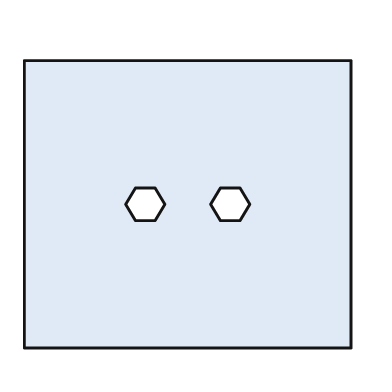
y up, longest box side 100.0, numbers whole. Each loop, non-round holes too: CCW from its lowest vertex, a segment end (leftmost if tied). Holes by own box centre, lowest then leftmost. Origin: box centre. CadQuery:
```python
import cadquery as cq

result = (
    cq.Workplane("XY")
    .moveTo(-50.0, -44.0)
    .lineTo(50.0, -44.0)
    .lineTo(50.0, 44.0)
    .lineTo(-50.0, 44.0)
    .close()
    .moveTo(-16.0, -5.0)
    .lineTo(-10.0, -5.0)
    .lineTo(-7.0, 0.0)
    .lineTo(-10.0, 5.0)
    .lineTo(-16.0, 5.0)
    .lineTo(-19.0, 0.0)
    .close()
    .moveTo(10.0, -5.0)
    .lineTo(16.0, -5.0)
    .lineTo(19.0, 0.0)
    .lineTo(16.0, 5.0)
    .lineTo(10.0, 5.0)
    .lineTo(7.0, 0.0)
    .close()
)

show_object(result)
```